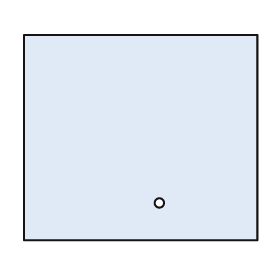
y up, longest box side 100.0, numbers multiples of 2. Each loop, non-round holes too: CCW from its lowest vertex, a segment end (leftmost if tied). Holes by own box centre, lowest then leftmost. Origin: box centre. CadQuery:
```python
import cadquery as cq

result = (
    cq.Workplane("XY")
    .moveTo(-50.0, -44.0)
    .lineTo(50.0, -44.0)
    .lineTo(50.0, 44.0)
    .lineTo(-50.0, 44.0)
    .close()
    .moveTo(8.0, -28.0)
    .circle(2.0)
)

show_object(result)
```